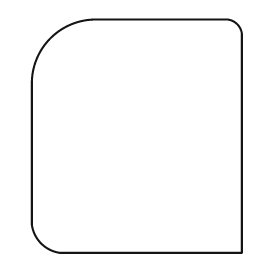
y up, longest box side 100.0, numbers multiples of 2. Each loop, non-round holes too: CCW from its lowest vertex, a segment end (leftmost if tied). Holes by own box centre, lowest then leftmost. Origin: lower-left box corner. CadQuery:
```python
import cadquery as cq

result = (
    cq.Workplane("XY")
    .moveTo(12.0, 0.0)
    .lineTo(90.0, 0.0)
    .lineTo(90.0, 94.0)
    .threePointArc((88.0, 98.0), (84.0, 100.0))
    .lineTo(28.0, 100.0)
    .threePointArc((8.0, 92.0), (0.0, 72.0))
    .lineTo(0.0, 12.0)
    .threePointArc((4.0, 4.0), (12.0, 0.0))
    .close()
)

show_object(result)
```